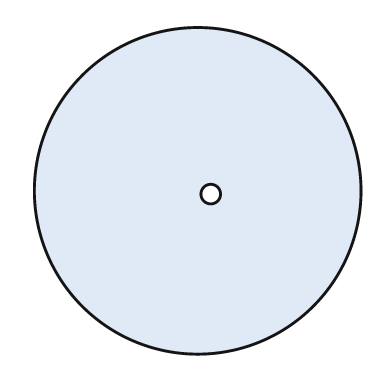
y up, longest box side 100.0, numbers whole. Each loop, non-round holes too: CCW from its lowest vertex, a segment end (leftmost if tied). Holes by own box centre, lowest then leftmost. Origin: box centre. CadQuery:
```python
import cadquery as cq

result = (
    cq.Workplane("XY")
    .moveTo(0.0, 0.0)
    .circle(50.0)
    .moveTo(4.0, -1.0)
    .circle(3.0)
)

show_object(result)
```